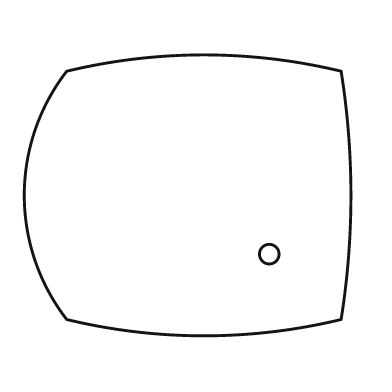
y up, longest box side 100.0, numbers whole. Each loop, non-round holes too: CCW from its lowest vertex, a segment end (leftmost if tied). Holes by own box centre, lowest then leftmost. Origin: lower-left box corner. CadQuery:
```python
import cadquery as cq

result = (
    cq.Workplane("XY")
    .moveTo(13.0, 5.0)
    .threePointArc((55.0, 0.0), (97.0, 5.0))
    .threePointArc((100.0, 43.0), (97.0, 81.0))
    .threePointArc((55.0, 86.0), (13.0, 81.0))
    .threePointArc((0.0, 43.0), (13.0, 5.0))
    .close()
    .moveTo(75.0, 25.0)
    .circle(3.0)
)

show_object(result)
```